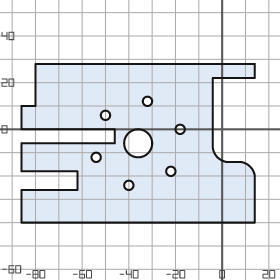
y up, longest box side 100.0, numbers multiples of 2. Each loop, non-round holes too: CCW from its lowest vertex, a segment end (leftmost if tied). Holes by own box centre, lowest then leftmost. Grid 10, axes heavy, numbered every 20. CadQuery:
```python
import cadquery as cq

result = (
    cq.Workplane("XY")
    .moveTo(-86.0, -40.0)
    .lineTo(14.0, -40.0)
    .lineTo(14.0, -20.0)
    .threePointArc((12.0, -16.0), (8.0, -14.0))
    .lineTo(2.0, -14.0)
    .threePointArc((-2.0, -12.0), (-4.0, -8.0))
    .lineTo(-4.0, 22.0)
    .lineTo(14.0, 22.0)
    .lineTo(14.0, 28.0)
    .lineTo(-80.0, 28.0)
    .lineTo(-80.0, 10.0)
    .lineTo(-86.0, 10.0)
    .lineTo(-86.0, 0.0)
    .lineTo(-46.0, 0.0)
    .lineTo(-46.0, -6.0)
    .lineTo(-86.0, -6.0)
    .lineTo(-86.0, -18.0)
    .lineTo(-62.0, -18.0)
    .lineTo(-62.0, -26.0)
    .lineTo(-86.0, -26.0)
    .close()
    .moveTo(-40.0, -24.0)
    .circle(2.0)
    .moveTo(-22.0, -18.0)
    .circle(2.0)
    .moveTo(-54.0, -12.0)
    .circle(2.0)
    .moveTo(-36.0, -6.0)
    .circle(6.0)
    .moveTo(-18.0, 0.0)
    .circle(2.0)
    .moveTo(-50.0, 6.0)
    .circle(2.0)
    .moveTo(-32.0, 12.0)
    .circle(2.0)
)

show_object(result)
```